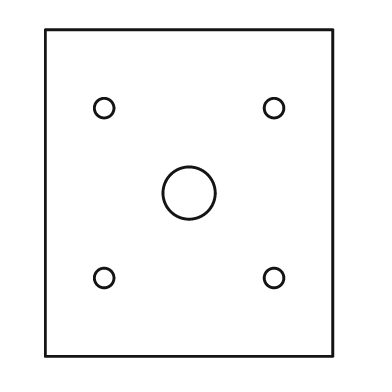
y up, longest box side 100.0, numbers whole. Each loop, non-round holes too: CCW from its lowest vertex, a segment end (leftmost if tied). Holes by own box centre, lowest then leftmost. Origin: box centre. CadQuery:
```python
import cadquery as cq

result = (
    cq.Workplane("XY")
    .moveTo(-44.0, -50.0)
    .lineTo(44.0, -50.0)
    .lineTo(44.0, 50.0)
    .lineTo(-44.0, 50.0)
    .close()
    .moveTo(-26.0, -26.0)
    .circle(3.0)
    .moveTo(26.0, -26.0)
    .circle(3.0)
    .moveTo(0.0, 0.0)
    .circle(8.0)
    .moveTo(-26.0, 26.0)
    .circle(3.0)
    .moveTo(26.0, 26.0)
    .circle(3.0)
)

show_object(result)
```